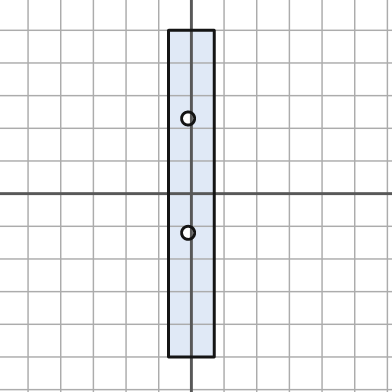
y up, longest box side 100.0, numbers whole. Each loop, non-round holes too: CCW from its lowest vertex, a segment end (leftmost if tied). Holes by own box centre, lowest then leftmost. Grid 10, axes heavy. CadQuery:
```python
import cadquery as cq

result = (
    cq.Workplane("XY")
    .moveTo(-7.0, -50.0)
    .lineTo(7.0, -50.0)
    .lineTo(7.0, 50.0)
    .lineTo(-7.0, 50.0)
    .close()
    .moveTo(-1.0, -12.0)
    .circle(2.0)
    .moveTo(-1.0, 23.0)
    .circle(2.0)
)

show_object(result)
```